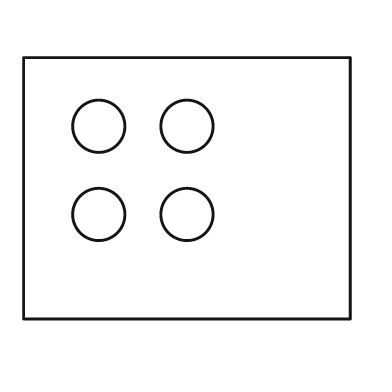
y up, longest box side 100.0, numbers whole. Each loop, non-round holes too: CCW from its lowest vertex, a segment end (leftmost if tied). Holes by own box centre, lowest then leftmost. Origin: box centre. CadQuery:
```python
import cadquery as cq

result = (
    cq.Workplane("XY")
    .moveTo(-50.0, -40.0)
    .lineTo(50.0, -40.0)
    .lineTo(50.0, 40.0)
    .lineTo(-50.0, 40.0)
    .close()
    .moveTo(-27.0, -8.0)
    .circle(8.0)
    .moveTo(0.0, -8.0)
    .circle(8.0)
    .moveTo(-27.0, 19.0)
    .circle(8.0)
    .moveTo(0.0, 19.0)
    .circle(8.0)
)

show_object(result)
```